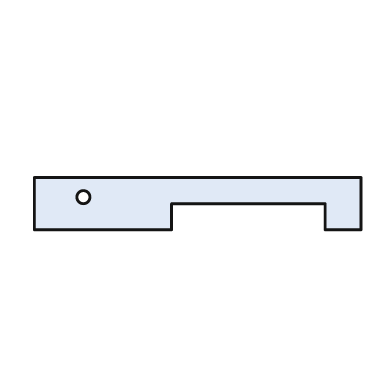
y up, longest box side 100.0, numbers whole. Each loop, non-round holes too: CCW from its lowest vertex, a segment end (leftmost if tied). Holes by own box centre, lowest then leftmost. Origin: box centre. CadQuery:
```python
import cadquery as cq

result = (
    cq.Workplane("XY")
    .moveTo(-50.0, -8.0)
    .lineTo(-8.0, -8.0)
    .lineTo(-8.0, 0.0)
    .lineTo(39.0, 0.0)
    .lineTo(39.0, -8.0)
    .lineTo(50.0, -8.0)
    .lineTo(50.0, 8.0)
    .lineTo(-50.0, 8.0)
    .close()
    .moveTo(-35.0, 2.0)
    .circle(2.0)
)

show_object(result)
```